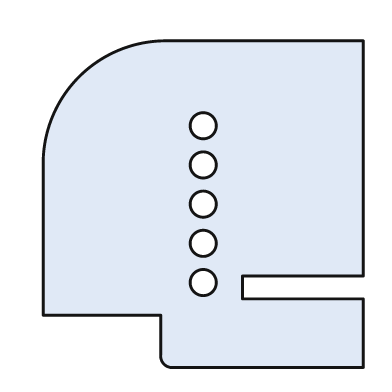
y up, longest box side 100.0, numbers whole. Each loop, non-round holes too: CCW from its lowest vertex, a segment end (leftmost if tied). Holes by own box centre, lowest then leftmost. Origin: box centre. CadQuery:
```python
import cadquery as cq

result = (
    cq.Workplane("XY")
    .moveTo(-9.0, -50.0)
    .lineTo(49.0, -50.0)
    .lineTo(49.0, -29.0)
    .lineTo(12.0, -29.0)
    .lineTo(12.0, -22.0)
    .lineTo(49.0, -22.0)
    .lineTo(49.0, 50.0)
    .lineTo(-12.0, 50.0)
    .threePointArc((-38.0, 39.0), (-49.0, 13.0))
    .lineTo(-49.0, -34.0)
    .lineTo(-13.0, -34.0)
    .lineTo(-13.0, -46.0)
    .threePointArc((-12.0, -49.0), (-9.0, -50.0))
    .close()
    .moveTo(0.0, -24.0)
    .circle(4.0)
    .moveTo(0.0, -12.0)
    .circle(4.0)
    .moveTo(0.0, 0.0)
    .circle(4.0)
    .moveTo(0.0, 12.0)
    .circle(4.0)
    .moveTo(0.0, 24.0)
    .circle(4.0)
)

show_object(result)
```